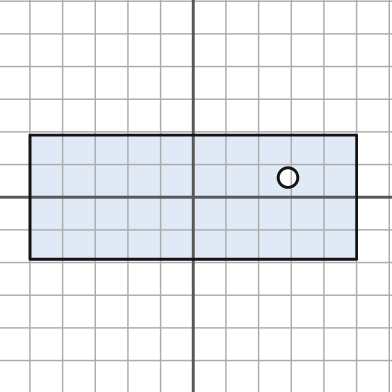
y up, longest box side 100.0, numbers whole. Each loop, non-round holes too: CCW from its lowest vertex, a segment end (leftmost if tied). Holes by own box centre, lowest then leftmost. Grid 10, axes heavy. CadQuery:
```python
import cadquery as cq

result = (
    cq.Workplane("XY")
    .moveTo(-50.0, -19.0)
    .lineTo(50.0, -19.0)
    .lineTo(50.0, 19.0)
    .lineTo(-50.0, 19.0)
    .close()
    .moveTo(29.0, 6.0)
    .circle(3.0)
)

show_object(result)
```